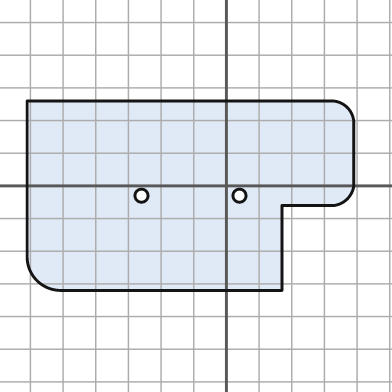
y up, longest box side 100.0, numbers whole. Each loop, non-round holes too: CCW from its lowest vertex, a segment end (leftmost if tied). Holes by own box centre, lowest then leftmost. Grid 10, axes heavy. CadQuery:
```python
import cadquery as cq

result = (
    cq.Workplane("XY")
    .moveTo(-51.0, -32.0)
    .lineTo(17.0, -32.0)
    .lineTo(17.0, -6.0)
    .lineTo(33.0, -6.0)
    .threePointArc((37.0, -4.0), (39.0, 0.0))
    .lineTo(39.0, 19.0)
    .threePointArc((37.0, 24.0), (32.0, 26.0))
    .lineTo(-61.0, 26.0)
    .lineTo(-61.0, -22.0)
    .threePointArc((-58.0, -29.0), (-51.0, -32.0))
    .close()
    .moveTo(-26.0, -3.0)
    .circle(2.0)
    .moveTo(4.0, -3.0)
    .circle(2.0)
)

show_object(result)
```